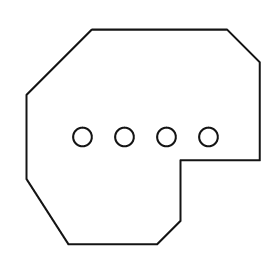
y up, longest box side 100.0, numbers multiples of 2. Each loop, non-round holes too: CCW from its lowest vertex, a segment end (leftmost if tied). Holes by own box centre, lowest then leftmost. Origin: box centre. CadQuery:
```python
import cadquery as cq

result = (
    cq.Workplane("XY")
    .moveTo(-32.0, -46.0)
    .lineTo(6.0, -46.0)
    .lineTo(16.0, -36.0)
    .lineTo(16.0, -10.0)
    .lineTo(50.0, -10.0)
    .lineTo(50.0, 32.0)
    .lineTo(36.0, 46.0)
    .lineTo(-22.0, 46.0)
    .lineTo(-50.0, 18.0)
    .lineTo(-50.0, -18.0)
    .close()
    .moveTo(-26.0, 0.0)
    .circle(4.0)
    .moveTo(-8.0, 0.0)
    .circle(4.0)
    .moveTo(10.0, 0.0)
    .circle(4.0)
    .moveTo(28.0, 0.0)
    .circle(4.0)
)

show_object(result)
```